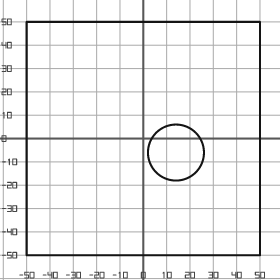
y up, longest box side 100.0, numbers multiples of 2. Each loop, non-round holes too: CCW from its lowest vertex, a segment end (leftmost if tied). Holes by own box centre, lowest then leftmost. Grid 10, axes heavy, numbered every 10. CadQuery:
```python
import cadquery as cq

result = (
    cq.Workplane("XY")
    .moveTo(-50.0, -50.0)
    .lineTo(50.0, -50.0)
    .lineTo(50.0, 50.0)
    .lineTo(-50.0, 50.0)
    .close()
    .moveTo(14.0, -6.0)
    .circle(12.0)
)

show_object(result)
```